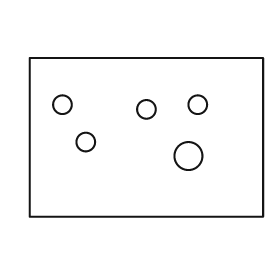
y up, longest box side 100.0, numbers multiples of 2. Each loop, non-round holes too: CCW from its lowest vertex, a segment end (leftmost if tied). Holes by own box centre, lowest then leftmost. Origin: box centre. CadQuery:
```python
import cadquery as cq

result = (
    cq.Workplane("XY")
    .moveTo(-50.0, -34.0)
    .lineTo(50.0, -34.0)
    .lineTo(50.0, 34.0)
    .lineTo(-50.0, 34.0)
    .close()
    .moveTo(18.0, -8.0)
    .circle(6.0)
    .moveTo(-26.0, -2.0)
    .circle(4.0)
    .moveTo(0.0, 12.0)
    .circle(4.0)
    .moveTo(-36.0, 14.0)
    .circle(4.0)
    .moveTo(22.0, 14.0)
    .circle(4.0)
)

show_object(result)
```